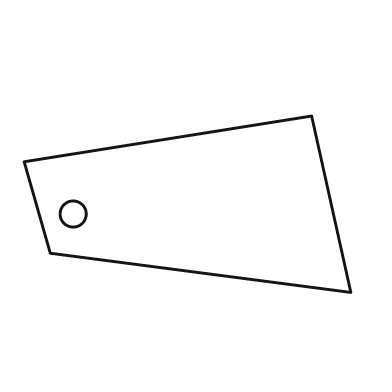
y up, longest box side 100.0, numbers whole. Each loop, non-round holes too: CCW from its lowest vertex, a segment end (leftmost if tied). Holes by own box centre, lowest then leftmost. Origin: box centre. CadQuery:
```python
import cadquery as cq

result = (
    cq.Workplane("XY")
    .moveTo(50.0, -27.0)
    .lineTo(38.0, 27.0)
    .lineTo(-50.0, 13.0)
    .lineTo(-42.0, -15.0)
    .close()
    .moveTo(-35.0, -3.0)
    .circle(4.0)
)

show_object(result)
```